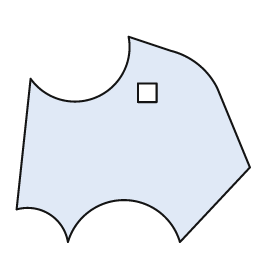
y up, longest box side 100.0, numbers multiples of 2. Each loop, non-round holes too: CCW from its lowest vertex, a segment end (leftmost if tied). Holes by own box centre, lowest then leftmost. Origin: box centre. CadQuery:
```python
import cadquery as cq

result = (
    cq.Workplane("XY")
    .moveTo(-28.0, -44.0)
    .threePointArc((-4.0, -26.0), (20.0, -44.0))
    .lineTo(50.0, -12.0)
    .lineTo(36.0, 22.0)
    .threePointArc((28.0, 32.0), (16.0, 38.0))
    .lineTo(-2.0, 44.0)
    .threePointArc((-16.0, 18.0), (-44.0, 26.0))
    .lineTo(-50.0, -30.0)
    .threePointArc((-36.0, -32.0), (-28.0, -44.0))
    .close()
    .moveTo(2.0, 16.0)
    .lineTo(10.0, 16.0)
    .lineTo(10.0, 24.0)
    .lineTo(2.0, 24.0)
    .close()
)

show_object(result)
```